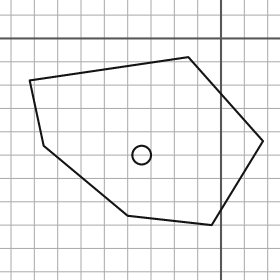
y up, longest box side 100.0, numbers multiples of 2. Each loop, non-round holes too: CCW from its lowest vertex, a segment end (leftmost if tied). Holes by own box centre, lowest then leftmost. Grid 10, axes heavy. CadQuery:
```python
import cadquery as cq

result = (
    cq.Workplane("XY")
    .moveTo(-4.0, -80.0)
    .lineTo(18.0, -44.0)
    .lineTo(-14.0, -8.0)
    .lineTo(-82.0, -18.0)
    .lineTo(-76.0, -46.0)
    .lineTo(-40.0, -76.0)
    .close()
    .moveTo(-34.0, -50.0)
    .circle(4.0)
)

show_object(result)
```